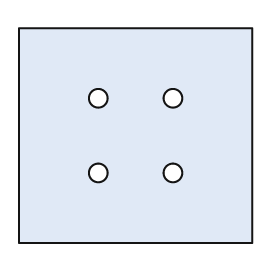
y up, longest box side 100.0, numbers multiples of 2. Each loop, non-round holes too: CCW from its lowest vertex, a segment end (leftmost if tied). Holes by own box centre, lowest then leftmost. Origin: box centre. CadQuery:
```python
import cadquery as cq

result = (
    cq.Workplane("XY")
    .moveTo(-50.0, -46.0)
    .lineTo(50.0, -46.0)
    .lineTo(50.0, 46.0)
    .lineTo(-50.0, 46.0)
    .close()
    .moveTo(-16.0, -16.0)
    .circle(4.0)
    .moveTo(16.0, -16.0)
    .circle(4.0)
    .moveTo(-16.0, 16.0)
    .circle(4.0)
    .moveTo(16.0, 16.0)
    .circle(4.0)
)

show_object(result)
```